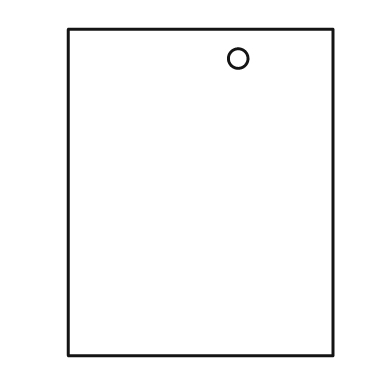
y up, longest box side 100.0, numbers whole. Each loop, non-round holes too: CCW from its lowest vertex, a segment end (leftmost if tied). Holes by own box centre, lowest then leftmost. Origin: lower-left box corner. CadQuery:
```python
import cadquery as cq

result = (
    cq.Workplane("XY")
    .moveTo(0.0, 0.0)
    .lineTo(81.0, 0.0)
    .lineTo(81.0, 100.0)
    .lineTo(0.0, 100.0)
    .close()
    .moveTo(52.0, 91.0)
    .circle(3.0)
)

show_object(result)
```